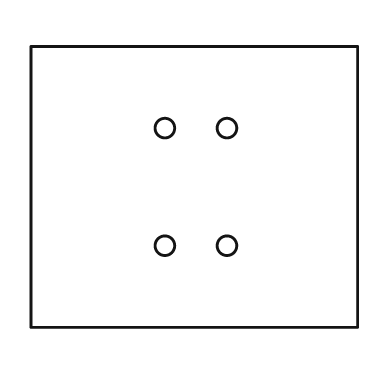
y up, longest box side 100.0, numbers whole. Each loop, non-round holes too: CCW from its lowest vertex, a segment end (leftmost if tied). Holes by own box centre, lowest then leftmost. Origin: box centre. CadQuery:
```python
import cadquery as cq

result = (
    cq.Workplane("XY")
    .moveTo(-50.0, -43.0)
    .lineTo(50.0, -43.0)
    .lineTo(50.0, 43.0)
    .lineTo(-50.0, 43.0)
    .close()
    .moveTo(-9.0, -18.0)
    .circle(3.0)
    .moveTo(10.0, -18.0)
    .circle(3.0)
    .moveTo(-9.0, 18.0)
    .circle(3.0)
    .moveTo(10.0, 18.0)
    .circle(3.0)
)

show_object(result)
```